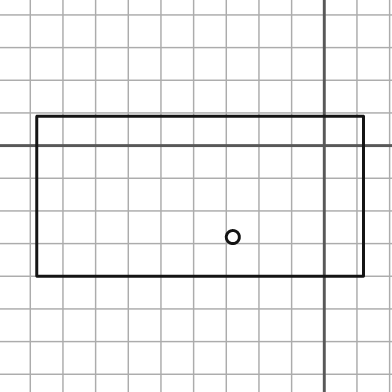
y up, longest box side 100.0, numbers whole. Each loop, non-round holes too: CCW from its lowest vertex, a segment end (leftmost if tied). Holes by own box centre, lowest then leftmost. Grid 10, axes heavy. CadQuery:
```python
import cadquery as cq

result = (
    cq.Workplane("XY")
    .moveTo(-88.0, -40.0)
    .lineTo(12.0, -40.0)
    .lineTo(12.0, 9.0)
    .lineTo(-88.0, 9.0)
    .close()
    .moveTo(-28.0, -28.0)
    .circle(2.0)
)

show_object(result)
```